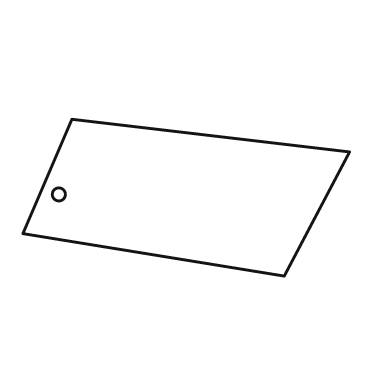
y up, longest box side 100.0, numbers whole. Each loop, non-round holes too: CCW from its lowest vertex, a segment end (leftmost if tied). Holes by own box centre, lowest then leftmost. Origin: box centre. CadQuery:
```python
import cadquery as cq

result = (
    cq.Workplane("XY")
    .moveTo(30.0, -24.0)
    .lineTo(50.0, 14.0)
    .lineTo(-35.0, 24.0)
    .lineTo(-50.0, -11.0)
    .close()
    .moveTo(-39.0, 1.0)
    .circle(2.0)
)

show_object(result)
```